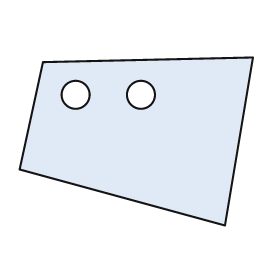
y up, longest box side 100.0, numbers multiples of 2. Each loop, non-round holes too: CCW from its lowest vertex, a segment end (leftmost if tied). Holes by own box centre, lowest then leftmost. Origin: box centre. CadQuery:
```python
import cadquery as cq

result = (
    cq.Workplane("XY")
    .moveTo(38.0, -36.0)
    .lineTo(50.0, 36.0)
    .lineTo(-40.0, 34.0)
    .lineTo(-50.0, -12.0)
    .close()
    .moveTo(-26.0, 20.0)
    .circle(6.0)
    .moveTo(2.0, 20.0)
    .circle(6.0)
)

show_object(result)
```